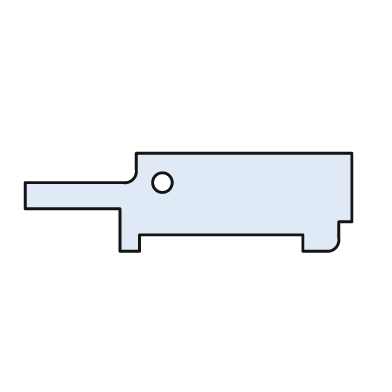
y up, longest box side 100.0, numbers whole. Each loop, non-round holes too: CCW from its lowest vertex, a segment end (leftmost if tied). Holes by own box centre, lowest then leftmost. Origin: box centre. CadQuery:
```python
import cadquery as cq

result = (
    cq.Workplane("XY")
    .moveTo(-21.0, -15.0)
    .lineTo(-15.0, -15.0)
    .lineTo(-15.0, -10.0)
    .lineTo(35.0, -10.0)
    .lineTo(35.0, -15.0)
    .lineTo(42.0, -15.0)
    .threePointArc((45.0, -14.0), (46.0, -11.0))
    .lineTo(46.0, -6.0)
    .lineTo(50.0, -6.0)
    .lineTo(50.0, 15.0)
    .lineTo(-16.0, 15.0)
    .lineTo(-16.0, 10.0)
    .threePointArc((-17.0, 7.0), (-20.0, 6.0))
    .lineTo(-50.0, 6.0)
    .lineTo(-50.0, -2.0)
    .lineTo(-21.0, -2.0)
    .close()
    .moveTo(-8.0, 6.0)
    .circle(3.0)
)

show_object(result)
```